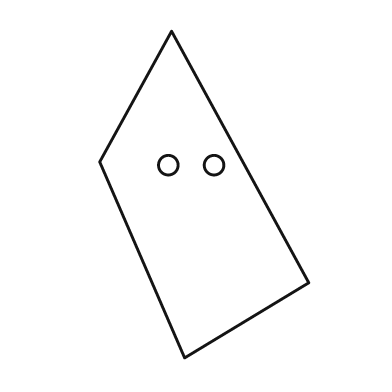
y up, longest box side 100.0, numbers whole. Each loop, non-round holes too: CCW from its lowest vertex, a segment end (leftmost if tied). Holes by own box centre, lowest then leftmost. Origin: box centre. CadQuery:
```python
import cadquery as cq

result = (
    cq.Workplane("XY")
    .moveTo(-6.0, -50.0)
    .lineTo(32.0, -27.0)
    .lineTo(-10.0, 50.0)
    .lineTo(-32.0, 10.0)
    .close()
    .moveTo(-11.0, 9.0)
    .circle(3.0)
    .moveTo(3.0, 9.0)
    .circle(3.0)
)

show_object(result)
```